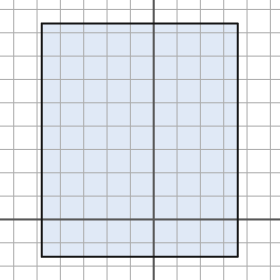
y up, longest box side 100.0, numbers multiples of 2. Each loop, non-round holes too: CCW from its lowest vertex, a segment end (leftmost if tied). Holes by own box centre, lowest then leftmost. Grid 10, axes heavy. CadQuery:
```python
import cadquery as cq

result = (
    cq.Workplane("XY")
    .moveTo(-48.0, -16.0)
    .lineTo(36.0, -16.0)
    .lineTo(36.0, 84.0)
    .lineTo(-48.0, 84.0)
    .close()
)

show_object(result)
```